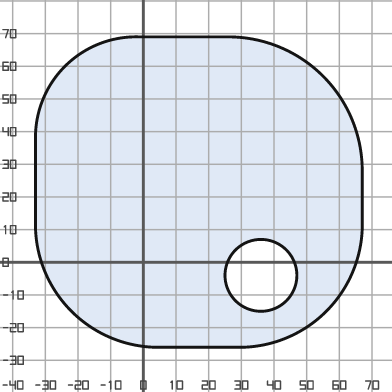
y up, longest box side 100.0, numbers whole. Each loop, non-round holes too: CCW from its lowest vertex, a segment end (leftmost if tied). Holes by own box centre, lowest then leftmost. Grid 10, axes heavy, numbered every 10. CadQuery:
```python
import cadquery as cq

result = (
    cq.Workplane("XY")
    .moveTo(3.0, -26.0)
    .lineTo(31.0, -26.0)
    .threePointArc((56.0, -15.0), (67.0, 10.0))
    .lineTo(67.0, 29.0)
    .threePointArc((55.0, 57.0), (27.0, 69.0))
    .lineTo(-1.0, 69.0)
    .threePointArc((-24.0, 60.0), (-33.0, 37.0))
    .lineTo(-33.0, 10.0)
    .threePointArc((-22.0, -15.0), (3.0, -26.0))
    .close()
    .moveTo(36.0, -4.0)
    .circle(11.0)
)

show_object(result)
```